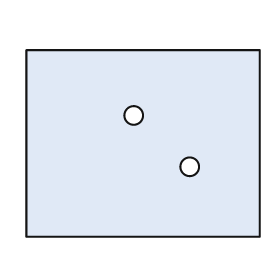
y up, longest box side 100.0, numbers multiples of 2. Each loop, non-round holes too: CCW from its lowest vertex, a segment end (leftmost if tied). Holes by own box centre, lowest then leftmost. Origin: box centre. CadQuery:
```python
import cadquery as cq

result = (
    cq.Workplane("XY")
    .moveTo(-50.0, -40.0)
    .lineTo(50.0, -40.0)
    .lineTo(50.0, 40.0)
    .lineTo(-50.0, 40.0)
    .close()
    .moveTo(20.0, -10.0)
    .circle(4.0)
    .moveTo(-4.0, 12.0)
    .circle(4.0)
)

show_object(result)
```